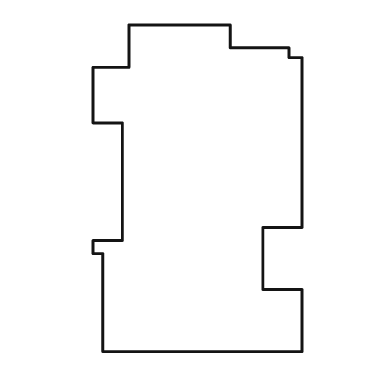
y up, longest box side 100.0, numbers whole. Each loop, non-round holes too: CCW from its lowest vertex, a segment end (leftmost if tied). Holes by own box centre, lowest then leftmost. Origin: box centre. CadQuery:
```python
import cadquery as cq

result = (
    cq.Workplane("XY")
    .moveTo(-29.0, -50.0)
    .lineTo(32.0, -50.0)
    .lineTo(32.0, -31.0)
    .lineTo(20.0, -31.0)
    .lineTo(20.0, -12.0)
    .lineTo(32.0, -12.0)
    .lineTo(32.0, 40.0)
    .lineTo(28.0, 40.0)
    .lineTo(28.0, 43.0)
    .lineTo(10.0, 43.0)
    .lineTo(10.0, 50.0)
    .lineTo(-21.0, 50.0)
    .lineTo(-21.0, 37.0)
    .lineTo(-32.0, 37.0)
    .lineTo(-32.0, 20.0)
    .lineTo(-23.0, 20.0)
    .lineTo(-23.0, -16.0)
    .lineTo(-32.0, -16.0)
    .lineTo(-32.0, -20.0)
    .lineTo(-29.0, -20.0)
    .close()
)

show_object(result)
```